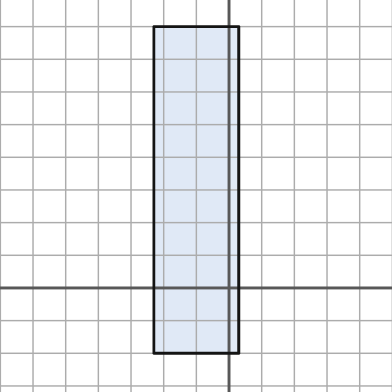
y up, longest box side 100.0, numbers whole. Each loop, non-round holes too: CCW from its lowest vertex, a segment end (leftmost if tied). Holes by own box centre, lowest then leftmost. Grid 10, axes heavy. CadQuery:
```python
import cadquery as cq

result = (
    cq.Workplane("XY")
    .moveTo(-23.0, -20.0)
    .lineTo(3.0, -20.0)
    .lineTo(3.0, 80.0)
    .lineTo(-23.0, 80.0)
    .close()
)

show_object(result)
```